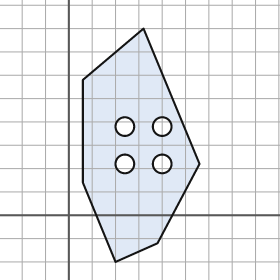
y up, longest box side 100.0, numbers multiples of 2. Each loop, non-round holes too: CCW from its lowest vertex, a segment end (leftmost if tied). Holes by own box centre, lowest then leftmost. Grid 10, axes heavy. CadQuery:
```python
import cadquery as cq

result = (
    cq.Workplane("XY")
    .moveTo(20.0, -20.0)
    .lineTo(38.0, -12.0)
    .lineTo(56.0, 22.0)
    .lineTo(32.0, 80.0)
    .lineTo(6.0, 58.0)
    .lineTo(6.0, 14.0)
    .close()
    .moveTo(24.0, 22.0)
    .circle(4.0)
    .moveTo(40.0, 22.0)
    .circle(4.0)
    .moveTo(24.0, 38.0)
    .circle(4.0)
    .moveTo(40.0, 38.0)
    .circle(4.0)
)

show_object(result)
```